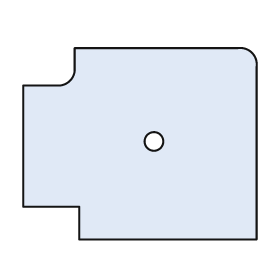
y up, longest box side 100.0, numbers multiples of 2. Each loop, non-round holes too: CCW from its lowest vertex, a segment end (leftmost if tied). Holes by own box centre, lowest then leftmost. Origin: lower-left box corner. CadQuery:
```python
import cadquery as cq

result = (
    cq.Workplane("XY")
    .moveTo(24.0, 0.0)
    .lineTo(100.0, 0.0)
    .lineTo(100.0, 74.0)
    .threePointArc((98.0, 80.0), (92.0, 82.0))
    .lineTo(22.0, 82.0)
    .lineTo(22.0, 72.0)
    .threePointArc((20.0, 68.0), (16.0, 66.0))
    .lineTo(0.0, 66.0)
    .lineTo(0.0, 14.0)
    .lineTo(24.0, 14.0)
    .close()
    .moveTo(56.0, 42.0)
    .circle(4.0)
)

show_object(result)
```